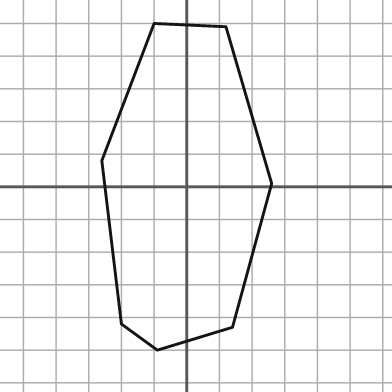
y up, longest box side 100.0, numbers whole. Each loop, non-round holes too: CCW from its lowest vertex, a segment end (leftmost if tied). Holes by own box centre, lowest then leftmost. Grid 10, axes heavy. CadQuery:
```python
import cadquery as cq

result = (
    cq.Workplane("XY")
    .moveTo(-9.0, -50.0)
    .lineTo(14.0, -43.0)
    .lineTo(26.0, 1.0)
    .lineTo(12.0, 49.0)
    .lineTo(-10.0, 50.0)
    .lineTo(-26.0, 8.0)
    .lineTo(-20.0, -42.0)
    .close()
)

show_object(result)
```